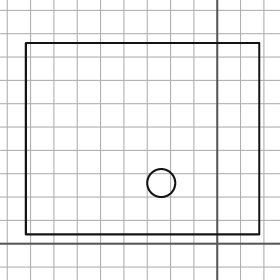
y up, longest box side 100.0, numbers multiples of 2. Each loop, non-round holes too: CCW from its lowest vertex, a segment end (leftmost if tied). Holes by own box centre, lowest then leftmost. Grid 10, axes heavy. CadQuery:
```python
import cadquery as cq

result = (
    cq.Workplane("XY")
    .moveTo(-82.0, 4.0)
    .lineTo(18.0, 4.0)
    .lineTo(18.0, 86.0)
    .lineTo(-82.0, 86.0)
    .close()
    .moveTo(-24.0, 26.0)
    .circle(6.0)
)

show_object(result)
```